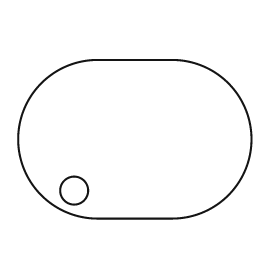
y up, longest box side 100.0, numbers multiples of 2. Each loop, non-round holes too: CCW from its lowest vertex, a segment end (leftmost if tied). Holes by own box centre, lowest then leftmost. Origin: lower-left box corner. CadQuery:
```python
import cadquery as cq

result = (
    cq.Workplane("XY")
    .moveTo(34.0, 0.0)
    .lineTo(66.0, 0.0)
    .threePointArc((100.0, 34.0), (66.0, 68.0))
    .lineTo(34.0, 68.0)
    .threePointArc((0.0, 34.0), (34.0, 0.0))
    .close()
    .moveTo(24.0, 12.0)
    .circle(6.0)
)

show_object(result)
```